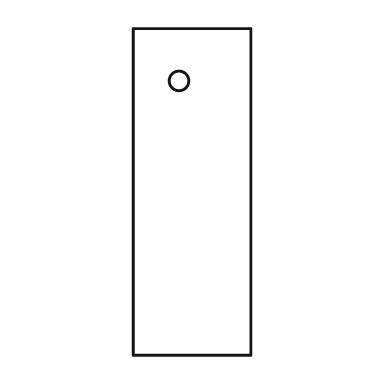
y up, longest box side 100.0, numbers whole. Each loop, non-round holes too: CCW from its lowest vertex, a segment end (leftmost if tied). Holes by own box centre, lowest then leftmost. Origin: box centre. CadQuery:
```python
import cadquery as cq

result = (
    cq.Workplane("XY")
    .moveTo(-18.0, -50.0)
    .lineTo(18.0, -50.0)
    .lineTo(18.0, 50.0)
    .lineTo(-18.0, 50.0)
    .close()
    .moveTo(-4.0, 34.0)
    .circle(3.0)
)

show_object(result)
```